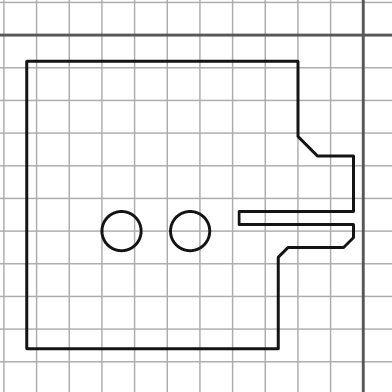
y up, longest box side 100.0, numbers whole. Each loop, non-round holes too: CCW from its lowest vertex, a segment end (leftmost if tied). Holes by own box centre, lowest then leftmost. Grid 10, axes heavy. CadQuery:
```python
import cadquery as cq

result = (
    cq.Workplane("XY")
    .moveTo(-103.0, -96.0)
    .lineTo(-26.0, -96.0)
    .lineTo(-26.0, -68.0)
    .lineTo(-23.0, -65.0)
    .lineTo(-6.0, -65.0)
    .lineTo(-3.0, -62.0)
    .lineTo(-3.0, -58.0)
    .lineTo(-38.0, -58.0)
    .lineTo(-38.0, -54.0)
    .lineTo(-3.0, -54.0)
    .lineTo(-3.0, -37.0)
    .lineTo(-14.0, -37.0)
    .lineTo(-20.0, -31.0)
    .lineTo(-20.0, -8.0)
    .lineTo(-103.0, -8.0)
    .close()
    .moveTo(-74.0, -60.0)
    .circle(6.0)
    .moveTo(-53.0, -60.0)
    .circle(6.0)
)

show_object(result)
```